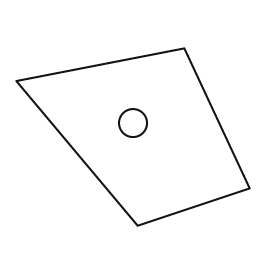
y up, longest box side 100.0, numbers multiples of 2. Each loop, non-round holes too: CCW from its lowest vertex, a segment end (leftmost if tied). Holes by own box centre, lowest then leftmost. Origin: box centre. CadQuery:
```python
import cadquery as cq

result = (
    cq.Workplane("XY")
    .moveTo(2.0, -38.0)
    .lineTo(50.0, -22.0)
    .lineTo(22.0, 38.0)
    .lineTo(-50.0, 24.0)
    .close()
    .moveTo(0.0, 6.0)
    .circle(6.0)
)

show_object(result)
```